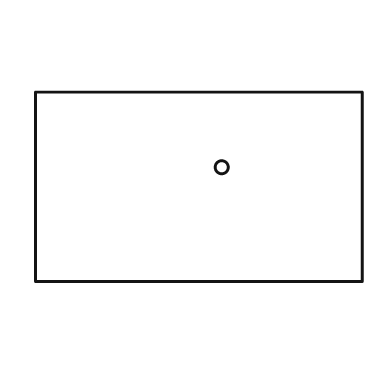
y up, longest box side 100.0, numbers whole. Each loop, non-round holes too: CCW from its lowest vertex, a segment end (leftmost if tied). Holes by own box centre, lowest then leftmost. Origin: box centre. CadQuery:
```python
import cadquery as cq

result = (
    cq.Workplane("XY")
    .moveTo(-50.0, -29.0)
    .lineTo(50.0, -29.0)
    .lineTo(50.0, 29.0)
    .lineTo(-50.0, 29.0)
    .close()
    .moveTo(7.0, 6.0)
    .circle(2.0)
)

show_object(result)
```